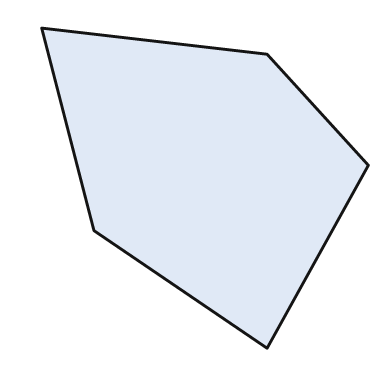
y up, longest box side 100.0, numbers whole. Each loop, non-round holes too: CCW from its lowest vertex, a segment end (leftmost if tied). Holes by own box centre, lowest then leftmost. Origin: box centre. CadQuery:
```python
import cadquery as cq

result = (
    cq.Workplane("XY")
    .moveTo(19.0, -49.0)
    .lineTo(50.0, 7.0)
    .lineTo(19.0, 41.0)
    .lineTo(-50.0, 49.0)
    .lineTo(-34.0, -13.0)
    .close()
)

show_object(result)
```